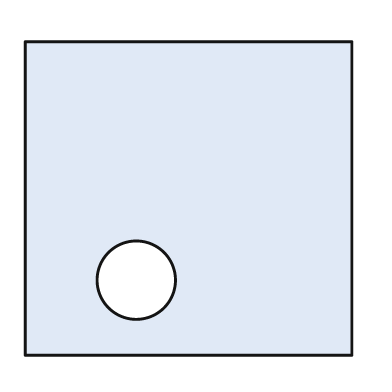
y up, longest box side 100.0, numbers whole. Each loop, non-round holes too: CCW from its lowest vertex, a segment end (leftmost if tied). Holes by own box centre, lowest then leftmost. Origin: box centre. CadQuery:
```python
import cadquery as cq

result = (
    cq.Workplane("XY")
    .moveTo(-50.0, -48.0)
    .lineTo(50.0, -48.0)
    .lineTo(50.0, 48.0)
    .lineTo(-50.0, 48.0)
    .close()
    .moveTo(-16.0, -25.0)
    .circle(12.0)
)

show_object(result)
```